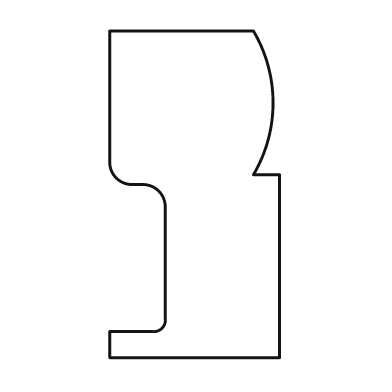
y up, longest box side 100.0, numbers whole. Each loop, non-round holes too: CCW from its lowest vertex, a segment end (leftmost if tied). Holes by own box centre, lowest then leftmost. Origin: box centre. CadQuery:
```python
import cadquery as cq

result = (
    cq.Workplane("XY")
    .moveTo(-26.0, -50.0)
    .lineTo(26.0, -50.0)
    .lineTo(26.0, 6.0)
    .lineTo(18.0, 6.0)
    .threePointArc((24.0, 28.0), (18.0, 50.0))
    .lineTo(-26.0, 50.0)
    .lineTo(-26.0, 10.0)
    .threePointArc((-24.0, 5.0), (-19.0, 3.0))
    .lineTo(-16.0, 3.0)
    .threePointArc((-11.0, 1.0), (-9.0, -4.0))
    .lineTo(-9.0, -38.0)
    .threePointArc((-10.0, -41.0), (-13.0, -42.0))
    .lineTo(-26.0, -42.0)
    .close()
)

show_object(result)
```